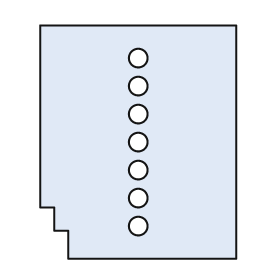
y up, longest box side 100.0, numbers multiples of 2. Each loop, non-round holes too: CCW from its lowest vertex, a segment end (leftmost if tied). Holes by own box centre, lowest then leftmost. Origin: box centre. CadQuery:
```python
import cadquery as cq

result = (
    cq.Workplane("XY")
    .moveTo(-30.0, -50.0)
    .lineTo(42.0, -50.0)
    .lineTo(42.0, 50.0)
    .lineTo(-42.0, 50.0)
    .lineTo(-42.0, -28.0)
    .lineTo(-36.0, -28.0)
    .lineTo(-36.0, -38.0)
    .lineTo(-30.0, -38.0)
    .close()
    .moveTo(0.0, -36.0)
    .circle(4.0)
    .moveTo(0.0, -24.0)
    .circle(4.0)
    .moveTo(0.0, -12.0)
    .circle(4.0)
    .moveTo(0.0, 0.0)
    .circle(4.0)
    .moveTo(0.0, 12.0)
    .circle(4.0)
    .moveTo(0.0, 24.0)
    .circle(4.0)
    .moveTo(0.0, 36.0)
    .circle(4.0)
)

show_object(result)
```